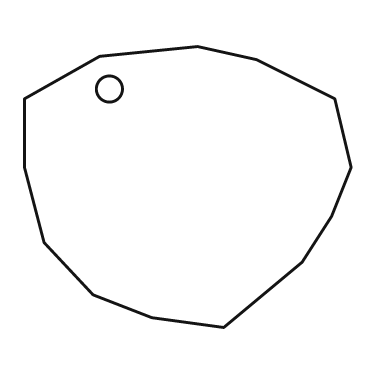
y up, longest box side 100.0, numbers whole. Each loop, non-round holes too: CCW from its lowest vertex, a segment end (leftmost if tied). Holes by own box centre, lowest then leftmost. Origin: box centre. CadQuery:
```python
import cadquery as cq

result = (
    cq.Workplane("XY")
    .moveTo(11.0, -43.0)
    .lineTo(35.0, -23.0)
    .lineTo(44.0, -9.0)
    .lineTo(50.0, 6.0)
    .lineTo(45.0, 27.0)
    .lineTo(21.0, 39.0)
    .lineTo(3.0, 43.0)
    .lineTo(-27.0, 40.0)
    .lineTo(-50.0, 27.0)
    .lineTo(-50.0, 6.0)
    .lineTo(-44.0, -17.0)
    .lineTo(-29.0, -33.0)
    .lineTo(-11.0, -40.0)
    .close()
    .moveTo(-24.0, 30.0)
    .circle(4.0)
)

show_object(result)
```